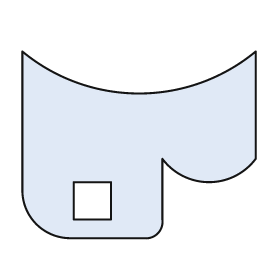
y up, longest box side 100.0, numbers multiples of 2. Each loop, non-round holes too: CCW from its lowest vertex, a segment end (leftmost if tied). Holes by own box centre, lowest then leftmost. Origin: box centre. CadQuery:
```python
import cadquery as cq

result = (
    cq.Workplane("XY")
    .moveTo(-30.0, -40.0)
    .lineTo(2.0, -40.0)
    .threePointArc((8.0, -38.0), (10.0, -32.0))
    .lineTo(10.0, -6.0)
    .threePointArc((30.0, -16.0), (50.0, -6.0))
    .lineTo(50.0, 40.0)
    .threePointArc((0.0, 22.0), (-50.0, 40.0))
    .lineTo(-50.0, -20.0)
    .threePointArc((-44.0, -34.0), (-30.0, -40.0))
    .close()
    .moveTo(-28.0, -32.0)
    .lineTo(-12.0, -32.0)
    .lineTo(-12.0, -16.0)
    .lineTo(-28.0, -16.0)
    .close()
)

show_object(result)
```